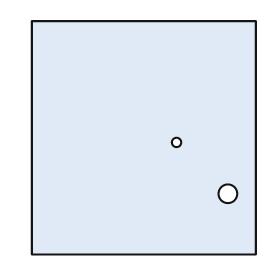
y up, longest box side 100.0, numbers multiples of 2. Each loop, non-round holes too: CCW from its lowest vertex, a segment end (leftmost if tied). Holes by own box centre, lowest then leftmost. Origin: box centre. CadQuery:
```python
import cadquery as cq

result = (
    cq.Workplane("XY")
    .moveTo(-48.0, -50.0)
    .lineTo(48.0, -50.0)
    .lineTo(48.0, 50.0)
    .lineTo(-48.0, 50.0)
    .close()
    .moveTo(36.0, -24.0)
    .circle(4.0)
    .moveTo(14.0, -2.0)
    .circle(2.0)
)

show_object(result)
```